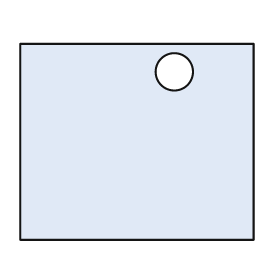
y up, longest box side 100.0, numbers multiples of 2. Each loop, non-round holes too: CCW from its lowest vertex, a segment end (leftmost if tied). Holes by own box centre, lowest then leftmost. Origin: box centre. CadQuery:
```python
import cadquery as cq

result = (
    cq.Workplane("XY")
    .moveTo(-50.0, -42.0)
    .lineTo(50.0, -42.0)
    .lineTo(50.0, 42.0)
    .lineTo(-50.0, 42.0)
    .close()
    .moveTo(16.0, 30.0)
    .circle(8.0)
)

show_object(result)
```